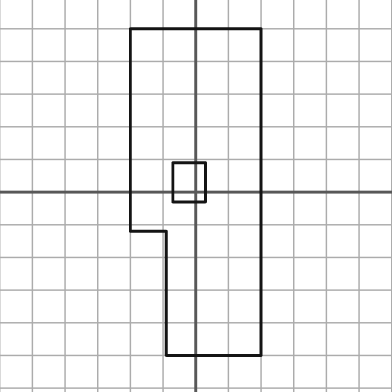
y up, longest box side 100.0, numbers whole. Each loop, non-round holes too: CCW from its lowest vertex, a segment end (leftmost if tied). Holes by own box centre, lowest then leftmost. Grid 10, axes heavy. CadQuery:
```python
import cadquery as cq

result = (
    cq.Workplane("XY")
    .moveTo(-9.0, -50.0)
    .lineTo(20.0, -50.0)
    .lineTo(20.0, 50.0)
    .lineTo(-20.0, 50.0)
    .lineTo(-20.0, -12.0)
    .lineTo(-9.0, -12.0)
    .close()
    .moveTo(-7.0, -3.0)
    .lineTo(3.0, -3.0)
    .lineTo(3.0, 9.0)
    .lineTo(-7.0, 9.0)
    .close()
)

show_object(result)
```